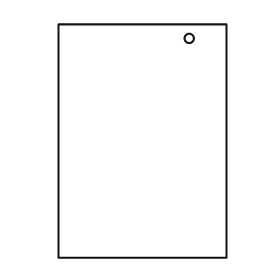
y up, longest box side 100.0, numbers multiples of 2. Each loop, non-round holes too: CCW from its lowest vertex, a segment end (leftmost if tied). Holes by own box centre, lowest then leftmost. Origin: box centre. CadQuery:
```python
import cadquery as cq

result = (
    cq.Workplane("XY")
    .moveTo(-36.0, -50.0)
    .lineTo(36.0, -50.0)
    .lineTo(36.0, 50.0)
    .lineTo(-36.0, 50.0)
    .close()
    .moveTo(20.0, 44.0)
    .circle(2.0)
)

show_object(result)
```